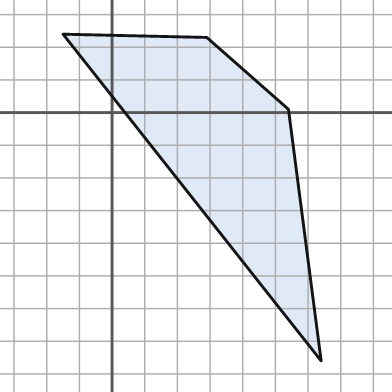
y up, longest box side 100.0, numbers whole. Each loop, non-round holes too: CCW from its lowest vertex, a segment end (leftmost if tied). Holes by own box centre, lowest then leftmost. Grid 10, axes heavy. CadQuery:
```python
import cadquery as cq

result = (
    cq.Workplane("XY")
    .moveTo(64.0, -76.0)
    .lineTo(54.0, 1.0)
    .lineTo(29.0, 23.0)
    .lineTo(-15.0, 24.0)
    .close()
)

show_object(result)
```